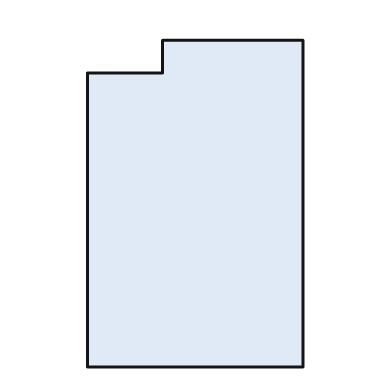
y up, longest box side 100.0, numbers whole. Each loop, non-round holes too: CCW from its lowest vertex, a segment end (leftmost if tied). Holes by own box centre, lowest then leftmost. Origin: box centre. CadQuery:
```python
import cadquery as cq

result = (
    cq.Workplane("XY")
    .moveTo(-33.0, -50.0)
    .lineTo(33.0, -50.0)
    .lineTo(33.0, 50.0)
    .lineTo(-10.0, 50.0)
    .lineTo(-10.0, 40.0)
    .lineTo(-33.0, 40.0)
    .close()
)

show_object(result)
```